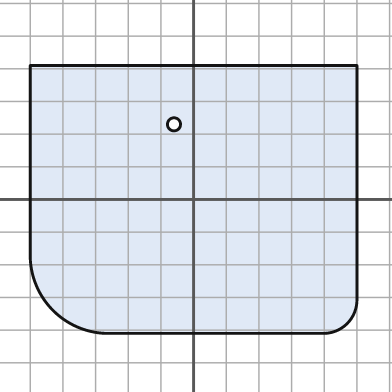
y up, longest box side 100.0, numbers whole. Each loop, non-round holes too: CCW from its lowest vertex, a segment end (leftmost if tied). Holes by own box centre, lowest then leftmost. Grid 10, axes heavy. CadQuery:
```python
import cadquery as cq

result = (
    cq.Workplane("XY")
    .moveTo(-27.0, -41.0)
    .lineTo(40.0, -41.0)
    .threePointArc((47.0, -38.0), (50.0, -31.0))
    .lineTo(50.0, 41.0)
    .lineTo(-50.0, 41.0)
    .lineTo(-50.0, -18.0)
    .threePointArc((-43.0, -34.0), (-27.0, -41.0))
    .close()
    .moveTo(-6.0, 23.0)
    .circle(2.0)
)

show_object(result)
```